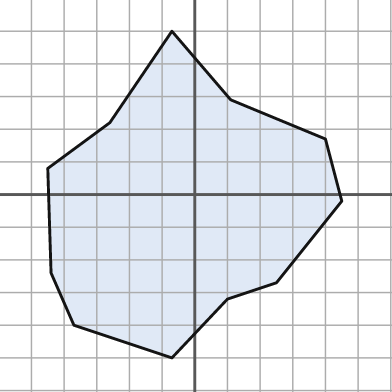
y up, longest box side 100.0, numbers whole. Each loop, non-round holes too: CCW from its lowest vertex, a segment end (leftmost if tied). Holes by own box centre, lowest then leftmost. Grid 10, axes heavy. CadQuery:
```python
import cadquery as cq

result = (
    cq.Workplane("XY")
    .moveTo(-7.0, -50.0)
    .lineTo(10.0, -32.0)
    .lineTo(25.0, -27.0)
    .lineTo(45.0, -2.0)
    .lineTo(40.0, 17.0)
    .lineTo(11.0, 29.0)
    .lineTo(-7.0, 50.0)
    .lineTo(-26.0, 22.0)
    .lineTo(-45.0, 8.0)
    .lineTo(-44.0, -24.0)
    .lineTo(-37.0, -40.0)
    .close()
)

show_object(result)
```